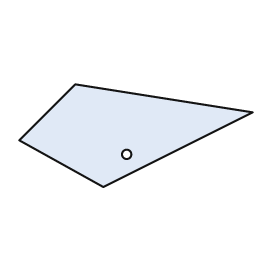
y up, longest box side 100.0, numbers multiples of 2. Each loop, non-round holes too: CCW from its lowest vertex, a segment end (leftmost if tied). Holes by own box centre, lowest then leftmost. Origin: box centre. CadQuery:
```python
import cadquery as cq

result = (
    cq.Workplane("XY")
    .moveTo(-14.0, -22.0)
    .lineTo(50.0, 10.0)
    .lineTo(-26.0, 22.0)
    .lineTo(-50.0, -2.0)
    .close()
    .moveTo(-4.0, -8.0)
    .circle(2.0)
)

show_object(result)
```